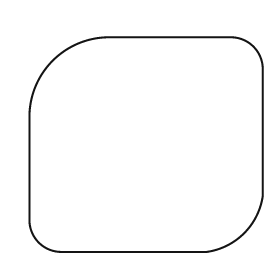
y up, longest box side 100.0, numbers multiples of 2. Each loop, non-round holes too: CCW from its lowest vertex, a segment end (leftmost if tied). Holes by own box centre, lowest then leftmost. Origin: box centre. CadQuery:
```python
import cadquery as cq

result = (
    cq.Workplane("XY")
    .moveTo(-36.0, -46.0)
    .lineTo(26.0, -46.0)
    .threePointArc((42.0, -38.0), (50.0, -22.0))
    .lineTo(50.0, 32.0)
    .threePointArc((46.0, 42.0), (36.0, 46.0))
    .lineTo(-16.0, 46.0)
    .threePointArc((-40.0, 36.0), (-50.0, 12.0))
    .lineTo(-50.0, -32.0)
    .threePointArc((-46.0, -42.0), (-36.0, -46.0))
    .close()
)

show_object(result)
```